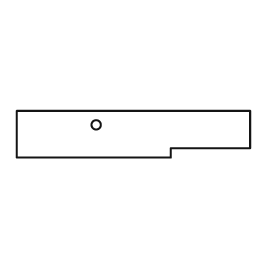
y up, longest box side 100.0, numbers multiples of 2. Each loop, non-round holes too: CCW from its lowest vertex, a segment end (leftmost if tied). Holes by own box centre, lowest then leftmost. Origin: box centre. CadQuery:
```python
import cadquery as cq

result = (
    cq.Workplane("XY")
    .moveTo(-50.0, -10.0)
    .lineTo(16.0, -10.0)
    .lineTo(16.0, -6.0)
    .lineTo(50.0, -6.0)
    .lineTo(50.0, 10.0)
    .lineTo(-50.0, 10.0)
    .close()
    .moveTo(-16.0, 4.0)
    .circle(2.0)
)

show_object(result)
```